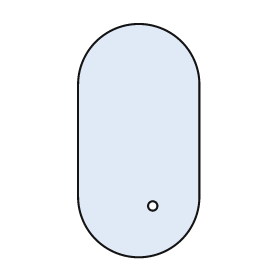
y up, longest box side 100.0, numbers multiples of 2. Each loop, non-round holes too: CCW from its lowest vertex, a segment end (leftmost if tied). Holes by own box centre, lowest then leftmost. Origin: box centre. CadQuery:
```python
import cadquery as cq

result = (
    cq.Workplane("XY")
    .moveTo(-26.0, -24.0)
    .threePointArc((0.0, -50.0), (26.0, -24.0))
    .lineTo(26.0, 24.0)
    .threePointArc((0.0, 50.0), (-26.0, 24.0))
    .close()
    .moveTo(6.0, -28.0)
    .circle(2.0)
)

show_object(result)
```